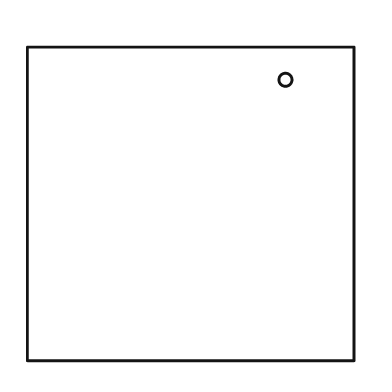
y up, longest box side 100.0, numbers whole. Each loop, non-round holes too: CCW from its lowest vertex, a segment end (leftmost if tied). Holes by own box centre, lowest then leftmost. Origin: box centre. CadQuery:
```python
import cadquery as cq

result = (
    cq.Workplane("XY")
    .moveTo(-50.0, -48.0)
    .lineTo(50.0, -48.0)
    .lineTo(50.0, 48.0)
    .lineTo(-50.0, 48.0)
    .close()
    .moveTo(29.0, 38.0)
    .circle(2.0)
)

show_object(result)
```